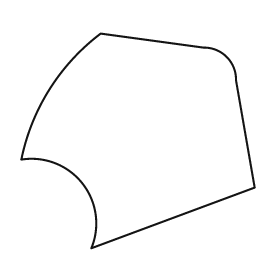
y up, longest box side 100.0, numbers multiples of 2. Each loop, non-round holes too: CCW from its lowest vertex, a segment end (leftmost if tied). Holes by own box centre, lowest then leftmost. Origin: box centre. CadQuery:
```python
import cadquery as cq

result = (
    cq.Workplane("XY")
    .moveTo(-20.0, -46.0)
    .lineTo(50.0, -20.0)
    .lineTo(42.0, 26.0)
    .threePointArc((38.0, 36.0), (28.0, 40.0))
    .lineTo(-16.0, 46.0)
    .threePointArc((-38.0, 22.0), (-50.0, -8.0))
    .threePointArc((-24.0, -18.0), (-20.0, -46.0))
    .close()
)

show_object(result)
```